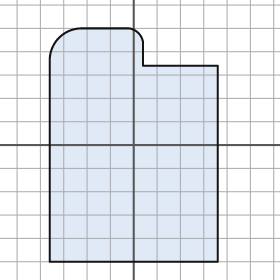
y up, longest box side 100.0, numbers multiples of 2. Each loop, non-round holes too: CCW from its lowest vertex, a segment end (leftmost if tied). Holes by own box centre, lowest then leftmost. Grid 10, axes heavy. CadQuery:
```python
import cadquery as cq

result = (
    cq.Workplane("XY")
    .moveTo(-36.0, -50.0)
    .lineTo(36.0, -50.0)
    .lineTo(36.0, 34.0)
    .lineTo(4.0, 34.0)
    .lineTo(4.0, 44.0)
    .threePointArc((2.0, 48.0), (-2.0, 50.0))
    .lineTo(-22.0, 50.0)
    .threePointArc((-32.0, 46.0), (-36.0, 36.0))
    .close()
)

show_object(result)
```